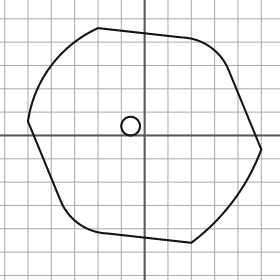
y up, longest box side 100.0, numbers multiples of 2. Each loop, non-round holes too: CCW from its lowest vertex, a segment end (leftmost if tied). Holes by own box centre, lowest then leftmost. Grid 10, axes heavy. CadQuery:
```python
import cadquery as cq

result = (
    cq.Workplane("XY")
    .moveTo(20.0, -46.0)
    .threePointArc((38.0, -28.0), (50.0, -6.0))
    .lineTo(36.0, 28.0)
    .threePointArc((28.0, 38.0), (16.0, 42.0))
    .lineTo(-20.0, 46.0)
    .threePointArc((-40.0, 30.0), (-50.0, 6.0))
    .lineTo(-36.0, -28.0)
    .threePointArc((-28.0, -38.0), (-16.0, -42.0))
    .close()
    .moveTo(-6.0, 4.0)
    .circle(4.0)
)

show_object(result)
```